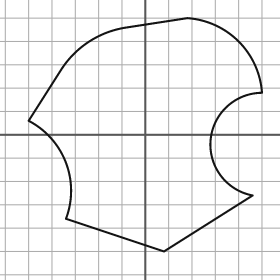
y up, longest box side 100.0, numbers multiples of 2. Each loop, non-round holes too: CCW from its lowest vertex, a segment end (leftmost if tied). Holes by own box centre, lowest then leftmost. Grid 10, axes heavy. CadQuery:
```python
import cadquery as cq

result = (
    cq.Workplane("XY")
    .moveTo(8.0, -50.0)
    .lineTo(46.0, -26.0)
    .threePointArc((28.0, -2.0), (50.0, 18.0))
    .threePointArc((40.0, 40.0), (18.0, 50.0))
    .lineTo(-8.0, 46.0)
    .threePointArc((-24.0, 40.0), (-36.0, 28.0))
    .lineTo(-50.0, 6.0)
    .threePointArc((-34.0, -12.0), (-34.0, -36.0))
    .close()
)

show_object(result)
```